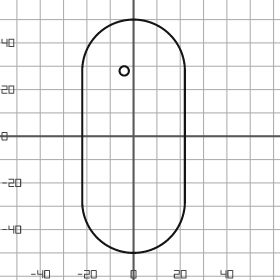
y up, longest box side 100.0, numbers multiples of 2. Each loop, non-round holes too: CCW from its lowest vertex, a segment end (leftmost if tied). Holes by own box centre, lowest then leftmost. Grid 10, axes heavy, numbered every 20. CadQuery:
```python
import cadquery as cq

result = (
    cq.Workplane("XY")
    .moveTo(-22.0, -28.0)
    .threePointArc((0.0, -50.0), (22.0, -28.0))
    .lineTo(22.0, 28.0)
    .threePointArc((0.0, 50.0), (-22.0, 28.0))
    .close()
    .moveTo(-4.0, 28.0)
    .circle(2.0)
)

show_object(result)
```